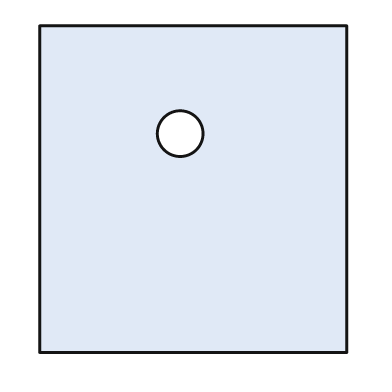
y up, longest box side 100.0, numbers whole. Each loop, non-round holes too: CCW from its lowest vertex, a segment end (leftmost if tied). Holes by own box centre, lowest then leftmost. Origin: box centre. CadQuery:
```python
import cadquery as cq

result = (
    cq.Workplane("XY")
    .moveTo(-47.0, -50.0)
    .lineTo(47.0, -50.0)
    .lineTo(47.0, 50.0)
    .lineTo(-47.0, 50.0)
    .close()
    .moveTo(-4.0, 17.0)
    .circle(7.0)
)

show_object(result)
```